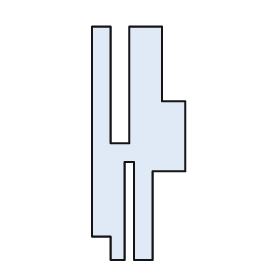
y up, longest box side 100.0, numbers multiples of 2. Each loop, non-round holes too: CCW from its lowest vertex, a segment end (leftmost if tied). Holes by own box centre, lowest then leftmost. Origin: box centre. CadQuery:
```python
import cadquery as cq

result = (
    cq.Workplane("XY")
    .moveTo(-12.0, -50.0)
    .lineTo(-6.0, -50.0)
    .lineTo(-6.0, -8.0)
    .lineTo(-2.0, -8.0)
    .lineTo(-2.0, -50.0)
    .lineTo(6.0, -50.0)
    .lineTo(6.0, -12.0)
    .lineTo(20.0, -12.0)
    .lineTo(20.0, 18.0)
    .lineTo(10.0, 18.0)
    .lineTo(10.0, 50.0)
    .lineTo(-4.0, 50.0)
    .lineTo(-4.0, 0.0)
    .lineTo(-12.0, 0.0)
    .lineTo(-12.0, 50.0)
    .lineTo(-20.0, 50.0)
    .lineTo(-20.0, -40.0)
    .lineTo(-12.0, -40.0)
    .close()
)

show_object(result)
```